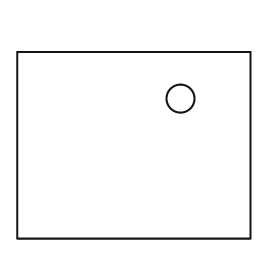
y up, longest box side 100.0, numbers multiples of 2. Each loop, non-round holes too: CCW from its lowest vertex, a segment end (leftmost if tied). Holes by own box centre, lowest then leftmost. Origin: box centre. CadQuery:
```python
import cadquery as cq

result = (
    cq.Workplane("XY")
    .moveTo(-50.0, -40.0)
    .lineTo(50.0, -40.0)
    .lineTo(50.0, 40.0)
    .lineTo(-50.0, 40.0)
    .close()
    .moveTo(20.0, 20.0)
    .circle(6.0)
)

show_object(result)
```